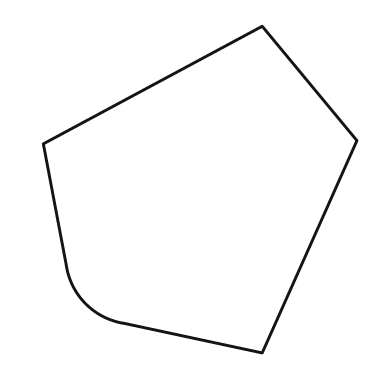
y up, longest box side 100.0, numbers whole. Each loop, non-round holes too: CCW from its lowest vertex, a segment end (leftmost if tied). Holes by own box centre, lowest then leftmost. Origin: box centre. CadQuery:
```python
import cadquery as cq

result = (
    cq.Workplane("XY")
    .moveTo(19.0, -50.0)
    .lineTo(48.0, 15.0)
    .lineTo(19.0, 50.0)
    .lineTo(-48.0, 14.0)
    .lineTo(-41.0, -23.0)
    .threePointArc((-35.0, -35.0), (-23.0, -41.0))
    .close()
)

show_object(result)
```